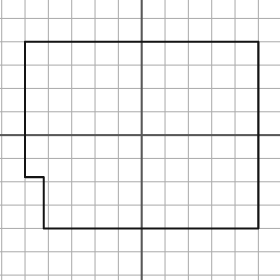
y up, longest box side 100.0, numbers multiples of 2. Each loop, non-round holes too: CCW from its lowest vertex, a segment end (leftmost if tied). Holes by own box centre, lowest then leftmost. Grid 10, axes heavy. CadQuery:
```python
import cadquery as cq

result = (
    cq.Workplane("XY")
    .moveTo(-42.0, -40.0)
    .lineTo(50.0, -40.0)
    .lineTo(50.0, 40.0)
    .lineTo(-50.0, 40.0)
    .lineTo(-50.0, -18.0)
    .lineTo(-42.0, -18.0)
    .close()
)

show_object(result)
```